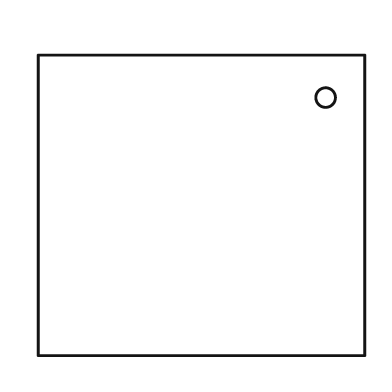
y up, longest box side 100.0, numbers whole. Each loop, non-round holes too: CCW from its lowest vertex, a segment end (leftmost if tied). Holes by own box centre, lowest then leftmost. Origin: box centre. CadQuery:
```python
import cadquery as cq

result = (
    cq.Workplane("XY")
    .moveTo(-50.0, -46.0)
    .lineTo(50.0, -46.0)
    .lineTo(50.0, 46.0)
    .lineTo(-50.0, 46.0)
    .close()
    .moveTo(38.0, 33.0)
    .circle(3.0)
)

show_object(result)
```